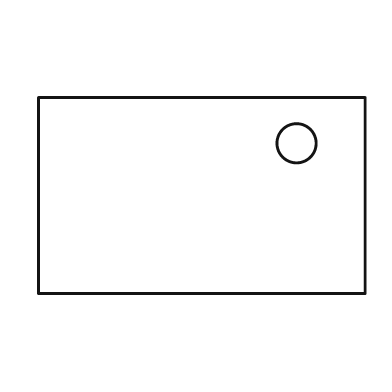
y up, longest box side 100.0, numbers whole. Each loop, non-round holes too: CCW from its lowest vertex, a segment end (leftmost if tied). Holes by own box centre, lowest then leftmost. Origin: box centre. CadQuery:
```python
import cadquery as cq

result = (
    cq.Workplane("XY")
    .moveTo(-50.0, -30.0)
    .lineTo(50.0, -30.0)
    .lineTo(50.0, 30.0)
    .lineTo(-50.0, 30.0)
    .close()
    .moveTo(29.0, 16.0)
    .circle(6.0)
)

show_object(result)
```